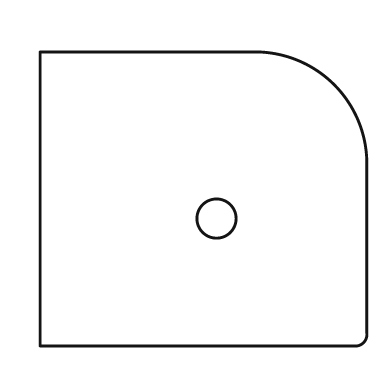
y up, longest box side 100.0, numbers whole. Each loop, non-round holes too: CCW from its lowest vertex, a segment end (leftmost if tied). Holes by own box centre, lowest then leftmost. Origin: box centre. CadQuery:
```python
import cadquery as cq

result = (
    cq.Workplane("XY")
    .moveTo(-50.0, -45.0)
    .lineTo(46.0, -45.0)
    .threePointArc((49.0, -44.0), (50.0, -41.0))
    .lineTo(50.0, 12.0)
    .threePointArc((40.0, 35.0), (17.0, 45.0))
    .lineTo(-50.0, 45.0)
    .close()
    .moveTo(4.0, -6.0)
    .circle(6.0)
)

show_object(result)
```